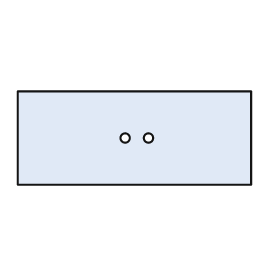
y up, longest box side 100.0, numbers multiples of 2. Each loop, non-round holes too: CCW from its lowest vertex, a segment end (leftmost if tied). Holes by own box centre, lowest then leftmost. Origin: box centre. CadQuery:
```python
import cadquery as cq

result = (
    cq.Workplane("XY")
    .moveTo(-50.0, -20.0)
    .lineTo(50.0, -20.0)
    .lineTo(50.0, 20.0)
    .lineTo(-50.0, 20.0)
    .close()
    .moveTo(-4.0, 0.0)
    .circle(2.0)
    .moveTo(6.0, 0.0)
    .circle(2.0)
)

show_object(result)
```